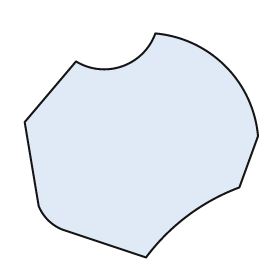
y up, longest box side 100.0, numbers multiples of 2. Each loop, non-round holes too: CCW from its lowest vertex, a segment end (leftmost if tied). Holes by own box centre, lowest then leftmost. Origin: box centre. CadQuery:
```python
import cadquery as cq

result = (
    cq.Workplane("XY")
    .moveTo(2.0, -48.0)
    .threePointArc((20.0, -30.0), (42.0, -18.0))
    .lineTo(50.0, 4.0)
    .threePointArc((36.0, 34.0), (6.0, 48.0))
    .threePointArc((-8.0, 34.0), (-28.0, 36.0))
    .lineTo(-50.0, 10.0)
    .lineTo(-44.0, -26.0)
    .threePointArc((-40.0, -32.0), (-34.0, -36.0))
    .close()
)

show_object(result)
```